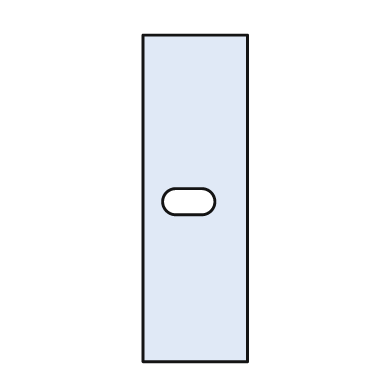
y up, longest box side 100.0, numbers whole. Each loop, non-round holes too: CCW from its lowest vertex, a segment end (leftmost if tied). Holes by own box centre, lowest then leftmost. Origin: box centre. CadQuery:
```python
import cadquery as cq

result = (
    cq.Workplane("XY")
    .moveTo(-16.0, -50.0)
    .lineTo(16.0, -50.0)
    .lineTo(16.0, 50.0)
    .lineTo(-16.0, 50.0)
    .close()
    .moveTo(-6.0, -5.0)
    .lineTo(2.0, -5.0)
    .threePointArc((6.0, -1.0), (2.0, 3.0))
    .lineTo(-6.0, 3.0)
    .threePointArc((-10.0, -1.0), (-6.0, -5.0))
    .close()
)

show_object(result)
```